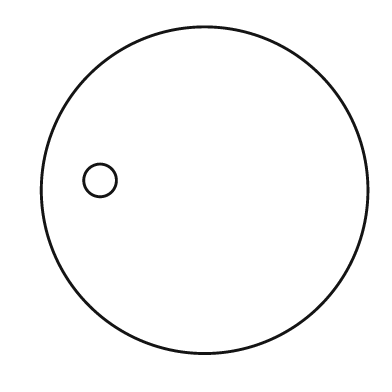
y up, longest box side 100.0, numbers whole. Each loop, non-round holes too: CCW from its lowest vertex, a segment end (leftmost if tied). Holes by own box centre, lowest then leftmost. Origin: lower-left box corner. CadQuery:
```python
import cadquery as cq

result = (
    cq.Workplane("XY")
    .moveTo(50.0, 50.0)
    .circle(50.0)
    .moveTo(18.0, 53.0)
    .circle(5.0)
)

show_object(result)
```